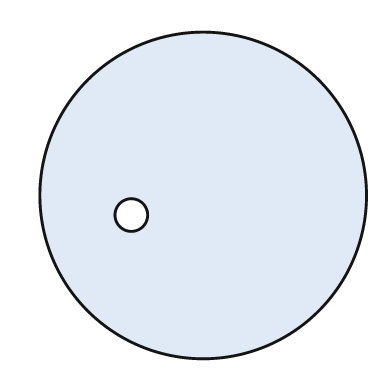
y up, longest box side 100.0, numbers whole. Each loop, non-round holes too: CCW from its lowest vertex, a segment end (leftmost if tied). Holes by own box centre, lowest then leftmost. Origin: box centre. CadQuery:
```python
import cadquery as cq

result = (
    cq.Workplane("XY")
    .moveTo(0.0, 0.0)
    .circle(50.0)
    .moveTo(-22.0, -6.0)
    .circle(5.0)
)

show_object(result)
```